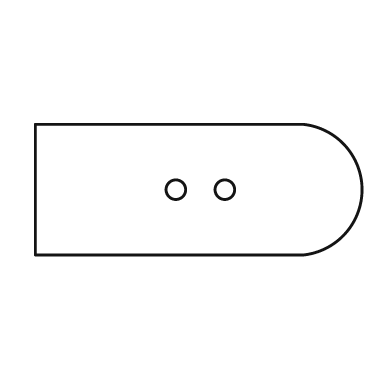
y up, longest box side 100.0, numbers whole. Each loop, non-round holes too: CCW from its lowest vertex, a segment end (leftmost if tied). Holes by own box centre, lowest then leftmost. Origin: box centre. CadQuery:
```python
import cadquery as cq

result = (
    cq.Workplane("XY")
    .moveTo(-50.0, -20.0)
    .lineTo(32.0, -20.0)
    .threePointArc((50.0, 0.0), (32.0, 20.0))
    .lineTo(-50.0, 20.0)
    .close()
    .moveTo(-7.0, 0.0)
    .circle(3.0)
    .moveTo(8.0, 0.0)
    .circle(3.0)
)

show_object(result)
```